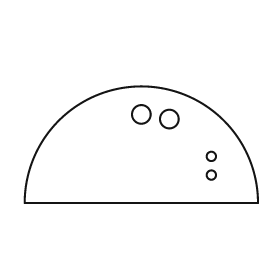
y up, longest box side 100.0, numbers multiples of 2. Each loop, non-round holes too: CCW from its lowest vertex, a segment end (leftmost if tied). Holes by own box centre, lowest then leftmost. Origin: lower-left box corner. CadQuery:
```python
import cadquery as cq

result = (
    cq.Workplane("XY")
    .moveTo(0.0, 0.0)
    .lineTo(100.0, 0.0)
    .threePointArc((50.0, 50.0), (0.0, 0.0))
    .close()
    .moveTo(80.0, 12.0)
    .circle(2.0)
    .moveTo(80.0, 20.0)
    .circle(2.0)
    .moveTo(62.0, 36.0)
    .circle(4.0)
    .moveTo(50.0, 38.0)
    .circle(4.0)
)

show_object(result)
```